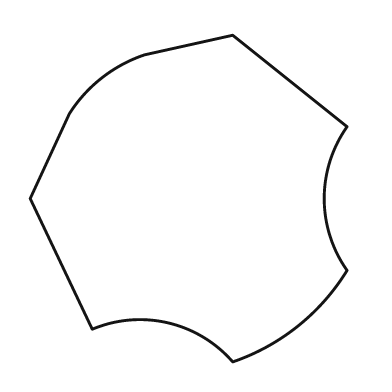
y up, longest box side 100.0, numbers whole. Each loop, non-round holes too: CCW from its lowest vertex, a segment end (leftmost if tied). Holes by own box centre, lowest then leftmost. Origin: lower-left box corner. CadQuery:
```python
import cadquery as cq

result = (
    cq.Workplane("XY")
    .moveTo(62.0, 0.0)
    .threePointArc((82.0, 11.0), (97.0, 28.0))
    .threePointArc((90.0, 50.0), (97.0, 72.0))
    .lineTo(62.0, 100.0)
    .lineTo(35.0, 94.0)
    .threePointArc((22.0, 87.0), (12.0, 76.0))
    .lineTo(0.0, 50.0)
    .lineTo(19.0, 10.0)
    .threePointArc((42.0, 12.0), (62.0, 0.0))
    .close()
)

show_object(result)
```